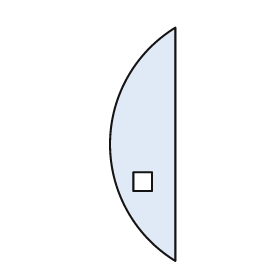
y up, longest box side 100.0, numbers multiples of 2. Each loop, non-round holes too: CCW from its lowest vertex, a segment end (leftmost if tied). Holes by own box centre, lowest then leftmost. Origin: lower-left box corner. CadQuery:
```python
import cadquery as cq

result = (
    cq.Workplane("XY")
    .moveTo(28.0, 0.0)
    .lineTo(28.0, 100.0)
    .threePointArc((0.0, 50.0), (28.0, 0.0))
    .close()
    .moveTo(10.0, 30.0)
    .lineTo(18.0, 30.0)
    .lineTo(18.0, 38.0)
    .lineTo(10.0, 38.0)
    .close()
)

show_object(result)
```